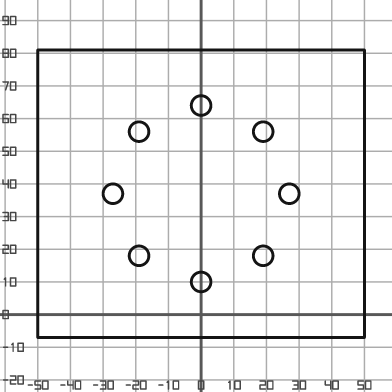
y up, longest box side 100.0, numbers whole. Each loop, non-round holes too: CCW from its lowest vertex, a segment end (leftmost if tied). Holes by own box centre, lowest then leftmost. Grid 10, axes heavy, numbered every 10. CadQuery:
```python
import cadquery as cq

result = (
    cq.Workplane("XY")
    .moveTo(-50.0, -7.0)
    .lineTo(50.0, -7.0)
    .lineTo(50.0, 81.0)
    .lineTo(-50.0, 81.0)
    .close()
    .moveTo(0.0, 10.0)
    .circle(3.0)
    .moveTo(-19.0, 18.0)
    .circle(3.0)
    .moveTo(19.0, 18.0)
    .circle(3.0)
    .moveTo(-27.0, 37.0)
    .circle(3.0)
    .moveTo(27.0, 37.0)
    .circle(3.0)
    .moveTo(-19.0, 56.0)
    .circle(3.0)
    .moveTo(19.0, 56.0)
    .circle(3.0)
    .moveTo(0.0, 64.0)
    .circle(3.0)
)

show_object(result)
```